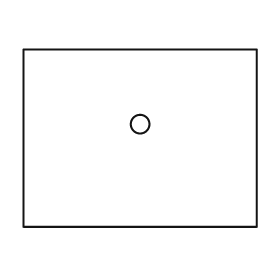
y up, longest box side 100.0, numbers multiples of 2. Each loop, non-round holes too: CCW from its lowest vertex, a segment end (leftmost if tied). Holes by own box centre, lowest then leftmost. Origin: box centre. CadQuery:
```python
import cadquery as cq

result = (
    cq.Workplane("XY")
    .moveTo(-50.0, -38.0)
    .lineTo(50.0, -38.0)
    .lineTo(50.0, 38.0)
    .lineTo(-50.0, 38.0)
    .close()
    .moveTo(0.0, 6.0)
    .circle(4.0)
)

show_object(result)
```